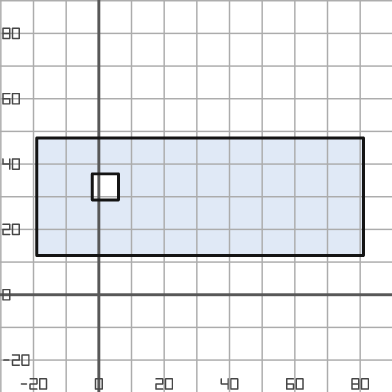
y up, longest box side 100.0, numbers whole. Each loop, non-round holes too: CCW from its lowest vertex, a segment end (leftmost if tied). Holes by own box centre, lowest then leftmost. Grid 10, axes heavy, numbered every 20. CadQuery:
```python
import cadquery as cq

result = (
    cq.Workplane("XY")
    .moveTo(-19.0, 12.0)
    .lineTo(81.0, 12.0)
    .lineTo(81.0, 48.0)
    .lineTo(-19.0, 48.0)
    .close()
    .moveTo(-2.0, 29.0)
    .lineTo(6.0, 29.0)
    .lineTo(6.0, 37.0)
    .lineTo(-2.0, 37.0)
    .close()
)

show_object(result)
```